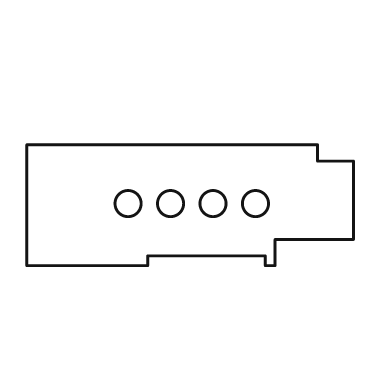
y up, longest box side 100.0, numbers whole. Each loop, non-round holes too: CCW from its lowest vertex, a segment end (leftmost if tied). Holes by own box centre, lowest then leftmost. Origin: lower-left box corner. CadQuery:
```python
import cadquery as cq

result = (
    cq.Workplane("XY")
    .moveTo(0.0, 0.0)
    .lineTo(37.0, 0.0)
    .lineTo(37.0, 3.0)
    .lineTo(73.0, 3.0)
    .lineTo(73.0, 0.0)
    .lineTo(76.0, 0.0)
    .lineTo(76.0, 8.0)
    .lineTo(100.0, 8.0)
    .lineTo(100.0, 32.0)
    .lineTo(89.0, 32.0)
    .lineTo(89.0, 37.0)
    .lineTo(0.0, 37.0)
    .close()
    .moveTo(31.0, 19.0)
    .circle(4.0)
    .moveTo(44.0, 19.0)
    .circle(4.0)
    .moveTo(57.0, 19.0)
    .circle(4.0)
    .moveTo(70.0, 19.0)
    .circle(4.0)
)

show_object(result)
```